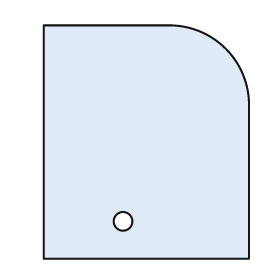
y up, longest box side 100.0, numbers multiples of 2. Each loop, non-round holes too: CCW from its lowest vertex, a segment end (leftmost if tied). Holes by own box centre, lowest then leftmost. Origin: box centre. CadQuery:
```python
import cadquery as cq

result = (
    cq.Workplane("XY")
    .moveTo(-44.0, -50.0)
    .lineTo(44.0, -50.0)
    .lineTo(44.0, 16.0)
    .threePointArc((34.0, 40.0), (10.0, 50.0))
    .lineTo(-44.0, 50.0)
    .close()
    .moveTo(-10.0, -34.0)
    .circle(4.0)
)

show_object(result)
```